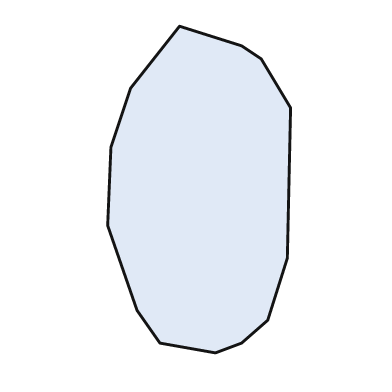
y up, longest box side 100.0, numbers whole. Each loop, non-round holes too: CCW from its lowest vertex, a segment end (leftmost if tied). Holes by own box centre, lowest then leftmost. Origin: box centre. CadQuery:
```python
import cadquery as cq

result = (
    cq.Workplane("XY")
    .moveTo(5.0, -50.0)
    .lineTo(13.0, -47.0)
    .lineTo(21.0, -40.0)
    .lineTo(27.0, -21.0)
    .lineTo(28.0, 25.0)
    .lineTo(19.0, 40.0)
    .lineTo(13.0, 44.0)
    .lineTo(-6.0, 50.0)
    .lineTo(-21.0, 31.0)
    .lineTo(-27.0, 13.0)
    .lineTo(-28.0, -11.0)
    .lineTo(-19.0, -37.0)
    .lineTo(-12.0, -47.0)
    .close()
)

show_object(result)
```